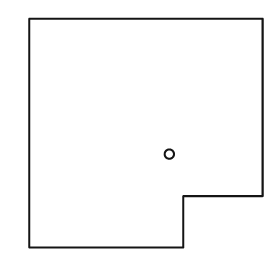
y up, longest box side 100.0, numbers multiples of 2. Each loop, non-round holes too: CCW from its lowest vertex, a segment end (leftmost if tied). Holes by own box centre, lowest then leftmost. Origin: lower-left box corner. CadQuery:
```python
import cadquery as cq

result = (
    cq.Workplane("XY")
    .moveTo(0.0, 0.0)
    .lineTo(66.0, 0.0)
    .lineTo(66.0, 22.0)
    .lineTo(100.0, 22.0)
    .lineTo(100.0, 98.0)
    .lineTo(0.0, 98.0)
    .close()
    .moveTo(60.0, 40.0)
    .circle(2.0)
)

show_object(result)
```